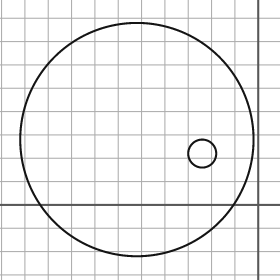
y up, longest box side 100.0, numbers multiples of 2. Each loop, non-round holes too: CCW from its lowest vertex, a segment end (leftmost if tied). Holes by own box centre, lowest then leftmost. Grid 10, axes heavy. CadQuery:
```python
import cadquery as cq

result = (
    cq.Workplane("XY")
    .moveTo(-52.0, 28.0)
    .circle(50.0)
    .moveTo(-24.0, 22.0)
    .circle(6.0)
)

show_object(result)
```